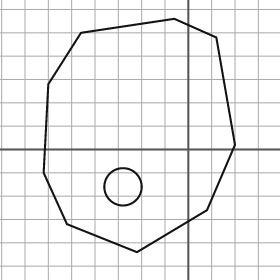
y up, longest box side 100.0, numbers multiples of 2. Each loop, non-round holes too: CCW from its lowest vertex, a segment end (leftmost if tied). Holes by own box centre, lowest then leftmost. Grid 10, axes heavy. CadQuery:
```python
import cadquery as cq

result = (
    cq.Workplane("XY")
    .moveTo(-22.0, -44.0)
    .lineTo(8.0, -26.0)
    .lineTo(20.0, 2.0)
    .lineTo(12.0, 48.0)
    .lineTo(-6.0, 56.0)
    .lineTo(-46.0, 50.0)
    .lineTo(-60.0, 28.0)
    .lineTo(-62.0, -10.0)
    .lineTo(-52.0, -32.0)
    .close()
    .moveTo(-28.0, -16.0)
    .circle(8.0)
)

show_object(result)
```